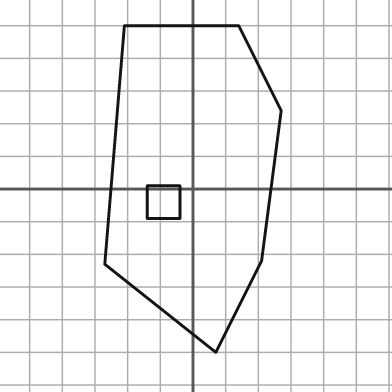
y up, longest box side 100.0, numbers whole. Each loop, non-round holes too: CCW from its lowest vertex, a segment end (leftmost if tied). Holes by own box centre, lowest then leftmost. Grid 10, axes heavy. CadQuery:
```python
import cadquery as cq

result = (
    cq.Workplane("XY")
    .moveTo(7.0, -50.0)
    .lineTo(21.0, -22.0)
    .lineTo(27.0, 24.0)
    .lineTo(14.0, 50.0)
    .lineTo(-21.0, 50.0)
    .lineTo(-27.0, -23.0)
    .close()
    .moveTo(-14.0, -9.0)
    .lineTo(-4.0, -9.0)
    .lineTo(-4.0, 1.0)
    .lineTo(-14.0, 1.0)
    .close()
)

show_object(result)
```